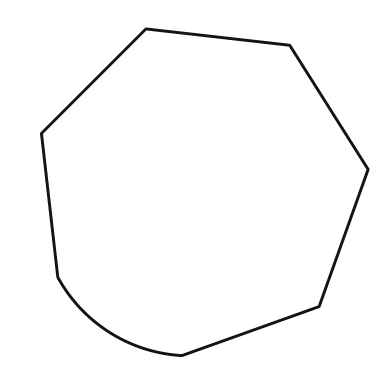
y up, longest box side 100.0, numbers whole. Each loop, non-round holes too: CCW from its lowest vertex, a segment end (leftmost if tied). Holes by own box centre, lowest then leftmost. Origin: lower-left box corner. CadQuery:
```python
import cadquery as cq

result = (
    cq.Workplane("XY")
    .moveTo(43.0, 0.0)
    .lineTo(85.0, 15.0)
    .lineTo(100.0, 57.0)
    .lineTo(76.0, 95.0)
    .lineTo(32.0, 100.0)
    .lineTo(0.0, 68.0)
    .lineTo(5.0, 24.0)
    .threePointArc((21.0, 7.0), (43.0, 0.0))
    .close()
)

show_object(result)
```